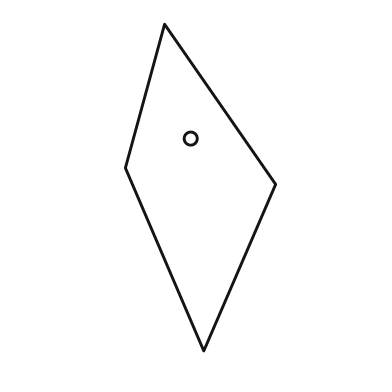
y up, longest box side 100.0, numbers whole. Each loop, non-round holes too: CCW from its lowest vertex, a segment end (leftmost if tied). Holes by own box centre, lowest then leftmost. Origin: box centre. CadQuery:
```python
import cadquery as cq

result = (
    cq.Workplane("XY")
    .moveTo(1.0, -50.0)
    .lineTo(23.0, 1.0)
    .lineTo(-11.0, 50.0)
    .lineTo(-23.0, 6.0)
    .close()
    .moveTo(-3.0, 15.0)
    .circle(2.0)
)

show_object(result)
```